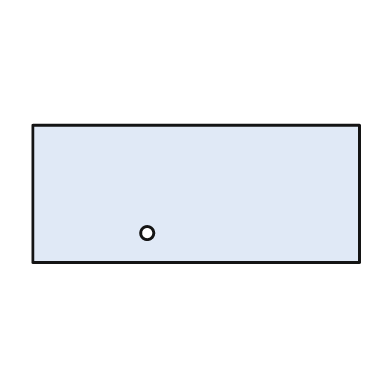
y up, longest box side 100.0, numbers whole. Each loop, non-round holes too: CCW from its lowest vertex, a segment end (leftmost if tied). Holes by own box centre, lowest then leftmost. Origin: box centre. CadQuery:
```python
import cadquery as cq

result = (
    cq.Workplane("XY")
    .moveTo(-50.0, -21.0)
    .lineTo(50.0, -21.0)
    .lineTo(50.0, 21.0)
    .lineTo(-50.0, 21.0)
    .close()
    .moveTo(-15.0, -12.0)
    .circle(2.0)
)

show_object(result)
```